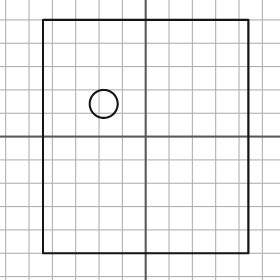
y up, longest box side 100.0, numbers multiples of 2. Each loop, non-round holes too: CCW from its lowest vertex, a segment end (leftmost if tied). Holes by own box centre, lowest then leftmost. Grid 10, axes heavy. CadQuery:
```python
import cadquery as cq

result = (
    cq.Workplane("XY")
    .moveTo(-44.0, -50.0)
    .lineTo(44.0, -50.0)
    .lineTo(44.0, 50.0)
    .lineTo(-44.0, 50.0)
    .close()
    .moveTo(-18.0, 14.0)
    .circle(6.0)
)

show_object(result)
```